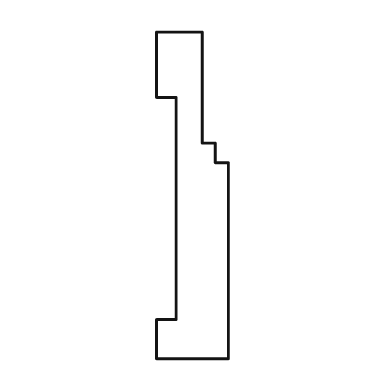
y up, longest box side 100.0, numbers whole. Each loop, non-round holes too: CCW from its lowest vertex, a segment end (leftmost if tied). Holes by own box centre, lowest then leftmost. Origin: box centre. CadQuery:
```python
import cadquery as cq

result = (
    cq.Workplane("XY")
    .moveTo(-11.0, -50.0)
    .lineTo(11.0, -50.0)
    .lineTo(11.0, 10.0)
    .lineTo(7.0, 10.0)
    .lineTo(7.0, 16.0)
    .lineTo(3.0, 16.0)
    .lineTo(3.0, 50.0)
    .lineTo(-11.0, 50.0)
    .lineTo(-11.0, 30.0)
    .lineTo(-5.0, 30.0)
    .lineTo(-5.0, -38.0)
    .lineTo(-11.0, -38.0)
    .close()
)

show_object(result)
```